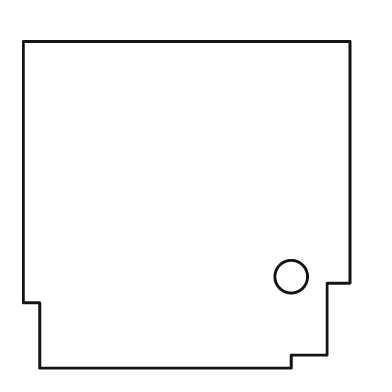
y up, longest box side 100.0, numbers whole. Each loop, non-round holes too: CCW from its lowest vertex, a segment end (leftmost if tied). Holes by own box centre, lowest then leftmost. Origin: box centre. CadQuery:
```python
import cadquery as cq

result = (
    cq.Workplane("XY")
    .moveTo(-45.0, -50.0)
    .lineTo(32.0, -50.0)
    .lineTo(32.0, -46.0)
    .lineTo(43.0, -46.0)
    .lineTo(43.0, -24.0)
    .lineTo(50.0, -24.0)
    .lineTo(50.0, 50.0)
    .lineTo(-50.0, 50.0)
    .lineTo(-50.0, -30.0)
    .lineTo(-45.0, -30.0)
    .close()
    .moveTo(32.0, -22.0)
    .circle(5.0)
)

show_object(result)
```